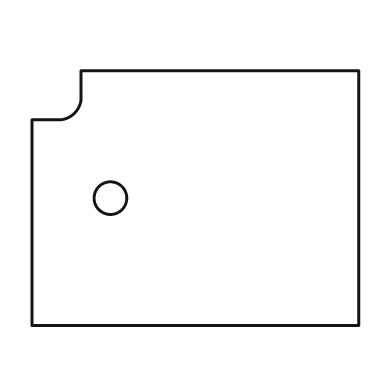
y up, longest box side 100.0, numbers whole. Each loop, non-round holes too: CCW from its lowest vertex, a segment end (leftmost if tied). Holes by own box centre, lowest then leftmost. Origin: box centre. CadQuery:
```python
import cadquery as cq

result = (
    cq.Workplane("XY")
    .moveTo(-50.0, -39.0)
    .lineTo(50.0, -39.0)
    .lineTo(50.0, 39.0)
    .lineTo(-35.0, 39.0)
    .lineTo(-35.0, 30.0)
    .threePointArc((-37.0, 26.0), (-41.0, 24.0))
    .lineTo(-50.0, 24.0)
    .close()
    .moveTo(-26.0, 0.0)
    .circle(5.0)
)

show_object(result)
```